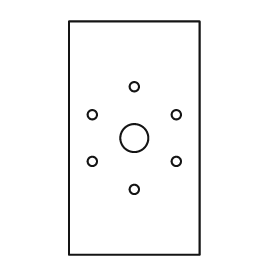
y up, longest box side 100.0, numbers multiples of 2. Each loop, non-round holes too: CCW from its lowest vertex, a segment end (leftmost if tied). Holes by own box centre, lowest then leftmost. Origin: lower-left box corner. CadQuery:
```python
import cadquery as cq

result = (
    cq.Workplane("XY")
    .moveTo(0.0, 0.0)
    .lineTo(56.0, 0.0)
    .lineTo(56.0, 100.0)
    .lineTo(0.0, 100.0)
    .close()
    .moveTo(28.0, 28.0)
    .circle(2.0)
    .moveTo(10.0, 40.0)
    .circle(2.0)
    .moveTo(46.0, 40.0)
    .circle(2.0)
    .moveTo(28.0, 50.0)
    .circle(6.0)
    .moveTo(10.0, 60.0)
    .circle(2.0)
    .moveTo(46.0, 60.0)
    .circle(2.0)
    .moveTo(28.0, 72.0)
    .circle(2.0)
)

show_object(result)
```